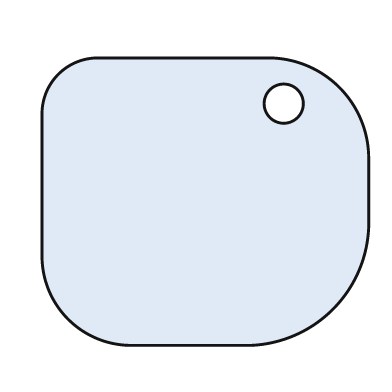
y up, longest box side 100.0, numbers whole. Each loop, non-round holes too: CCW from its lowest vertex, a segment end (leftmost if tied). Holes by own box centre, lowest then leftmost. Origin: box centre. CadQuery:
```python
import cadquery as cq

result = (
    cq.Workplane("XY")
    .moveTo(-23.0, -44.0)
    .lineTo(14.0, -44.0)
    .threePointArc((39.0, -33.0), (50.0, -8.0))
    .lineTo(50.0, 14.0)
    .threePointArc((41.0, 35.0), (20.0, 44.0))
    .lineTo(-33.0, 44.0)
    .threePointArc((-45.0, 39.0), (-50.0, 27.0))
    .lineTo(-50.0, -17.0)
    .threePointArc((-42.0, -36.0), (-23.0, -44.0))
    .close()
    .moveTo(24.0, 30.0)
    .circle(6.0)
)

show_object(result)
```